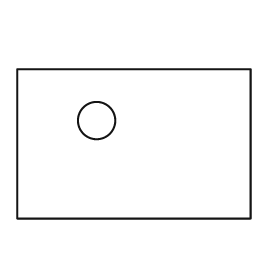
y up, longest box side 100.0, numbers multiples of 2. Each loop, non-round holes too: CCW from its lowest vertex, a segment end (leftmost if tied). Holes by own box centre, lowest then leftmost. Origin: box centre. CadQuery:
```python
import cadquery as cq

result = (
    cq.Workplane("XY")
    .moveTo(-50.0, -32.0)
    .lineTo(50.0, -32.0)
    .lineTo(50.0, 32.0)
    .lineTo(-50.0, 32.0)
    .close()
    .moveTo(-16.0, 10.0)
    .circle(8.0)
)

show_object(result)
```